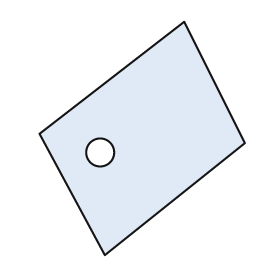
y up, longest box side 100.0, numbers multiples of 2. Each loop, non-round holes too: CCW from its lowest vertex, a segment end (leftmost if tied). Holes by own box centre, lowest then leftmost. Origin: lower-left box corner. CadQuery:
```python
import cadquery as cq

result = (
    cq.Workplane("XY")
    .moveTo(28.0, 0.0)
    .lineTo(88.0, 48.0)
    .lineTo(62.0, 100.0)
    .lineTo(0.0, 52.0)
    .close()
    .moveTo(26.0, 44.0)
    .circle(6.0)
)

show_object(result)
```